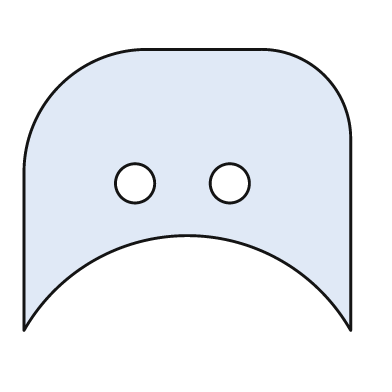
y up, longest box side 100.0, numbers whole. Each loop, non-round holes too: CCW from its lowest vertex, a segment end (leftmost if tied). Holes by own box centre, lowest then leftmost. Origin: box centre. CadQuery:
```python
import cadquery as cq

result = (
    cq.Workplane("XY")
    .moveTo(-50.0, -43.0)
    .threePointArc((0.0, -14.0), (50.0, -43.0))
    .lineTo(50.0, 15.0)
    .threePointArc((42.0, 35.0), (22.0, 43.0))
    .lineTo(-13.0, 43.0)
    .threePointArc((-39.0, 32.0), (-50.0, 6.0))
    .close()
    .moveTo(-16.0, 2.0)
    .circle(6.0)
    .moveTo(13.0, 2.0)
    .circle(6.0)
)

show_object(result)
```